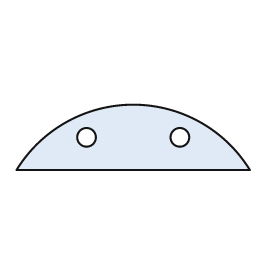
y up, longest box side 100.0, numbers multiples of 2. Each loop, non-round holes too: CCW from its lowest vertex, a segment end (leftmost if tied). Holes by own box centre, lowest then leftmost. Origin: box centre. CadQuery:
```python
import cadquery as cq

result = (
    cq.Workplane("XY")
    .moveTo(-50.0, -14.0)
    .lineTo(50.0, -14.0)
    .threePointArc((0.0, 14.0), (-50.0, -14.0))
    .close()
    .moveTo(-20.0, 0.0)
    .circle(4.0)
    .moveTo(20.0, 0.0)
    .circle(4.0)
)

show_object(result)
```